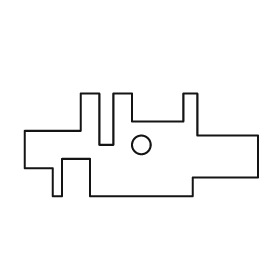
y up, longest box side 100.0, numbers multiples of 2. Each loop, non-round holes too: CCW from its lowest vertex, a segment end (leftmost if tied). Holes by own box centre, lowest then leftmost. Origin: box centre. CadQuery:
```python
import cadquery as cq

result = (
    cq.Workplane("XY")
    .moveTo(-38.0, -22.0)
    .lineTo(-34.0, -22.0)
    .lineTo(-34.0, -6.0)
    .lineTo(-22.0, -6.0)
    .lineTo(-22.0, -22.0)
    .lineTo(22.0, -22.0)
    .lineTo(22.0, -14.0)
    .lineTo(50.0, -14.0)
    .lineTo(50.0, 4.0)
    .lineTo(24.0, 4.0)
    .lineTo(24.0, 22.0)
    .lineTo(18.0, 22.0)
    .lineTo(18.0, 10.0)
    .lineTo(-4.0, 10.0)
    .lineTo(-4.0, 22.0)
    .lineTo(-12.0, 22.0)
    .lineTo(-12.0, 0.0)
    .lineTo(-18.0, 0.0)
    .lineTo(-18.0, 22.0)
    .lineTo(-26.0, 22.0)
    .lineTo(-26.0, 6.0)
    .lineTo(-50.0, 6.0)
    .lineTo(-50.0, -10.0)
    .lineTo(-38.0, -10.0)
    .close()
    .moveTo(0.0, 0.0)
    .circle(4.0)
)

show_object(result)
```